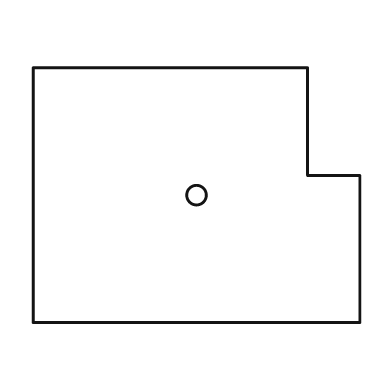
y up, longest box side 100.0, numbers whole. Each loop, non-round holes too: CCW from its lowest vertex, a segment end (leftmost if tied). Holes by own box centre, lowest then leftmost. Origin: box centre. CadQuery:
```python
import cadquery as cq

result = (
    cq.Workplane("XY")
    .moveTo(-50.0, -39.0)
    .lineTo(50.0, -39.0)
    .lineTo(50.0, 6.0)
    .lineTo(34.0, 6.0)
    .lineTo(34.0, 39.0)
    .lineTo(-50.0, 39.0)
    .close()
    .moveTo(0.0, 0.0)
    .circle(3.0)
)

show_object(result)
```